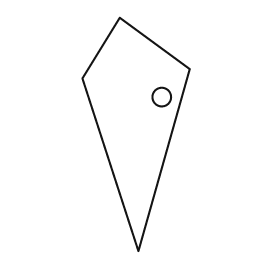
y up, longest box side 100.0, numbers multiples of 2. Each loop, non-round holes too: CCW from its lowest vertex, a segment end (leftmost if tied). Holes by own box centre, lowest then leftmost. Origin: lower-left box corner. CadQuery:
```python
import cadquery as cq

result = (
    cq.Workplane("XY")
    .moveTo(24.0, 0.0)
    .lineTo(46.0, 78.0)
    .lineTo(16.0, 100.0)
    .lineTo(0.0, 74.0)
    .close()
    .moveTo(34.0, 66.0)
    .circle(4.0)
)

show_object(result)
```